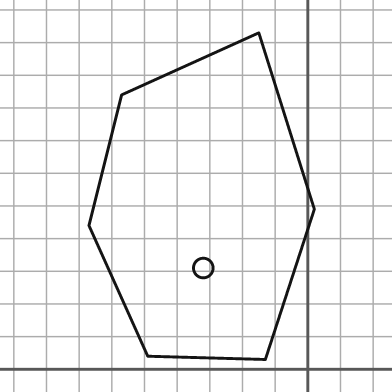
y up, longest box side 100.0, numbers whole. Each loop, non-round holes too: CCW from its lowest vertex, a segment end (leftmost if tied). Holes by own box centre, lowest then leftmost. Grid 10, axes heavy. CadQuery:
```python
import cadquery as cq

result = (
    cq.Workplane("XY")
    .moveTo(-13.0, 3.0)
    .lineTo(2.0, 49.0)
    .lineTo(-15.0, 103.0)
    .lineTo(-57.0, 84.0)
    .lineTo(-67.0, 44.0)
    .lineTo(-49.0, 4.0)
    .close()
    .moveTo(-32.0, 31.0)
    .circle(3.0)
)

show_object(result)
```